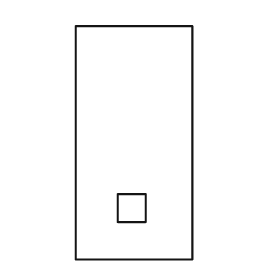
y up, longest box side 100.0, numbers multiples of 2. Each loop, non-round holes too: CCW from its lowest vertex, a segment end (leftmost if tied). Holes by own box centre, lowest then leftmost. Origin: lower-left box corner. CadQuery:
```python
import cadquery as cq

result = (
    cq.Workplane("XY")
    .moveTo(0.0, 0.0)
    .lineTo(50.0, 0.0)
    .lineTo(50.0, 100.0)
    .lineTo(0.0, 100.0)
    .close()
    .moveTo(18.0, 16.0)
    .lineTo(30.0, 16.0)
    .lineTo(30.0, 28.0)
    .lineTo(18.0, 28.0)
    .close()
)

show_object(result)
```